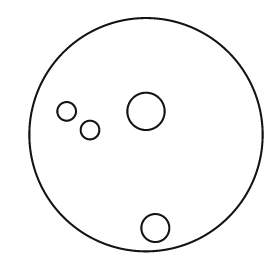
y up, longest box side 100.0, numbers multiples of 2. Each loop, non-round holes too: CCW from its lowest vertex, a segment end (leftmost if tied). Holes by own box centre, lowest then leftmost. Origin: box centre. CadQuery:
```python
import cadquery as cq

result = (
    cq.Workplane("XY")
    .moveTo(0.0, 0.0)
    .circle(50.0)
    .moveTo(4.0, -40.0)
    .circle(6.0)
    .moveTo(-24.0, 2.0)
    .circle(4.0)
    .moveTo(-34.0, 10.0)
    .circle(4.0)
    .moveTo(0.0, 10.0)
    .circle(8.0)
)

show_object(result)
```